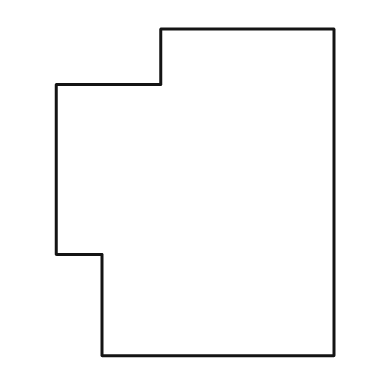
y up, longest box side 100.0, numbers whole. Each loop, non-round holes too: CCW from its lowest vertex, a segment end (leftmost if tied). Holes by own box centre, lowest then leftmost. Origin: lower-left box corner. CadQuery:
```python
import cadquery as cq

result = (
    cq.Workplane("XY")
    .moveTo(14.0, 0.0)
    .lineTo(85.0, 0.0)
    .lineTo(85.0, 100.0)
    .lineTo(32.0, 100.0)
    .lineTo(32.0, 83.0)
    .lineTo(0.0, 83.0)
    .lineTo(0.0, 31.0)
    .lineTo(14.0, 31.0)
    .close()
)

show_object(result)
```